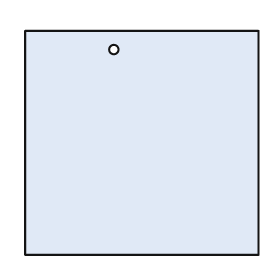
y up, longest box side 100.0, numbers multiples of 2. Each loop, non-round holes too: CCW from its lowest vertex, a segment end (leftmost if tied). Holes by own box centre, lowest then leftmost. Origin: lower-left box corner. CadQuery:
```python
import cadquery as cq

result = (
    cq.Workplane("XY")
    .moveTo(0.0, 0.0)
    .lineTo(100.0, 0.0)
    .lineTo(100.0, 96.0)
    .lineTo(0.0, 96.0)
    .close()
    .moveTo(38.0, 88.0)
    .circle(2.0)
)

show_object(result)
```